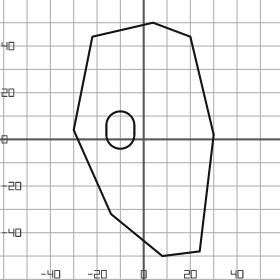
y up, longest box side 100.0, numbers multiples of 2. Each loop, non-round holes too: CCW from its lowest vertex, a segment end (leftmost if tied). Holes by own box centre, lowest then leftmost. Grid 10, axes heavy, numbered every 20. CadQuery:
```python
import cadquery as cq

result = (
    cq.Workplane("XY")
    .moveTo(8.0, -50.0)
    .lineTo(24.0, -48.0)
    .lineTo(30.0, 2.0)
    .lineTo(20.0, 44.0)
    .lineTo(4.0, 50.0)
    .lineTo(-22.0, 44.0)
    .lineTo(-30.0, 4.0)
    .lineTo(-14.0, -32.0)
    .close()
    .moveTo(-16.0, 2.0)
    .threePointArc((-10.0, -4.0), (-4.0, 2.0))
    .lineTo(-4.0, 6.0)
    .threePointArc((-10.0, 12.0), (-16.0, 6.0))
    .close()
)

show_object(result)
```